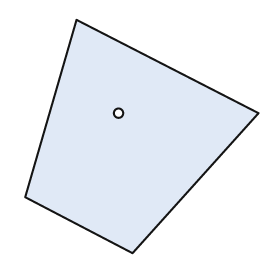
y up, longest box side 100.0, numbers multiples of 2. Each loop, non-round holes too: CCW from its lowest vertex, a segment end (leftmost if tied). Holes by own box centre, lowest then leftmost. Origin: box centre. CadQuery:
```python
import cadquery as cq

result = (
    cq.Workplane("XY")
    .moveTo(-4.0, -50.0)
    .lineTo(50.0, 10.0)
    .lineTo(-28.0, 50.0)
    .lineTo(-50.0, -26.0)
    .close()
    .moveTo(-10.0, 10.0)
    .circle(2.0)
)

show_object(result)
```